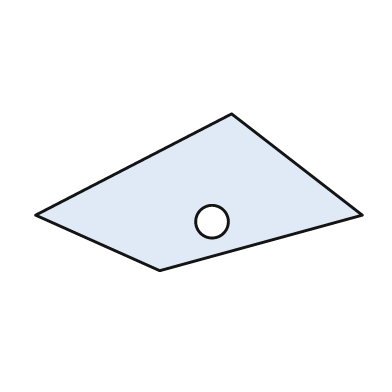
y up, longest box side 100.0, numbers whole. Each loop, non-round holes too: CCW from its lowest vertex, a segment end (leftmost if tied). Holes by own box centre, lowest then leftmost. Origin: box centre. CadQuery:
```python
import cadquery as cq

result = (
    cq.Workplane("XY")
    .moveTo(-12.0, -24.0)
    .lineTo(50.0, -7.0)
    .lineTo(10.0, 24.0)
    .lineTo(-50.0, -7.0)
    .close()
    .moveTo(4.0, -9.0)
    .circle(5.0)
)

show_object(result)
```